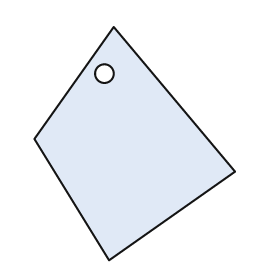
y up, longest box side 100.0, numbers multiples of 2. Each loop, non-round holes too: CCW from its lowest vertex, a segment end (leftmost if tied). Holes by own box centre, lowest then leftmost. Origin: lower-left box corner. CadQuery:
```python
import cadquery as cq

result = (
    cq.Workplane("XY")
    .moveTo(32.0, 0.0)
    .lineTo(86.0, 38.0)
    .lineTo(34.0, 100.0)
    .lineTo(0.0, 52.0)
    .close()
    .moveTo(30.0, 80.0)
    .circle(4.0)
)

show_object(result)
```